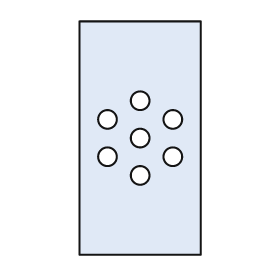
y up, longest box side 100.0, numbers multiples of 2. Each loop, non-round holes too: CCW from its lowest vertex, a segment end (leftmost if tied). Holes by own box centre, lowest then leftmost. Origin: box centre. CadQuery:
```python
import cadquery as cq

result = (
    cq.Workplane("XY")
    .moveTo(-26.0, -50.0)
    .lineTo(26.0, -50.0)
    .lineTo(26.0, 50.0)
    .lineTo(-26.0, 50.0)
    .close()
    .moveTo(0.0, -16.0)
    .circle(4.0)
    .moveTo(-14.0, -8.0)
    .circle(4.0)
    .moveTo(14.0, -8.0)
    .circle(4.0)
    .moveTo(0.0, 0.0)
    .circle(4.0)
    .moveTo(-14.0, 8.0)
    .circle(4.0)
    .moveTo(14.0, 8.0)
    .circle(4.0)
    .moveTo(0.0, 16.0)
    .circle(4.0)
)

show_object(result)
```